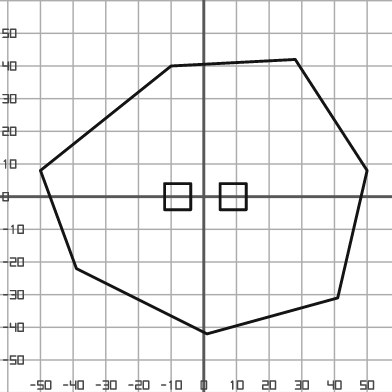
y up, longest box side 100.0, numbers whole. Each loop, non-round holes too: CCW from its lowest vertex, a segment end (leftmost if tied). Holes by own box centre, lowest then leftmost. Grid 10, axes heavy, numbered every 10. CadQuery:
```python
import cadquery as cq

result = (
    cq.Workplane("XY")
    .moveTo(1.0, -42.0)
    .lineTo(41.0, -31.0)
    .lineTo(50.0, 8.0)
    .lineTo(28.0, 42.0)
    .lineTo(-10.0, 40.0)
    .lineTo(-50.0, 8.0)
    .lineTo(-39.0, -22.0)
    .close()
    .moveTo(-12.0, -4.0)
    .lineTo(-4.0, -4.0)
    .lineTo(-4.0, 4.0)
    .lineTo(-12.0, 4.0)
    .close()
    .moveTo(5.0, -4.0)
    .lineTo(13.0, -4.0)
    .lineTo(13.0, 4.0)
    .lineTo(5.0, 4.0)
    .close()
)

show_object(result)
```